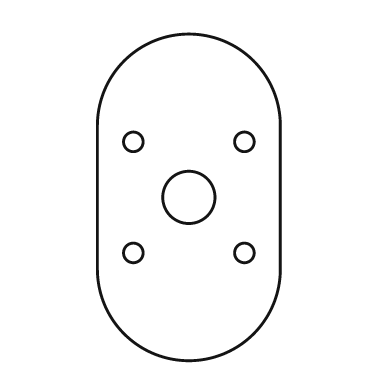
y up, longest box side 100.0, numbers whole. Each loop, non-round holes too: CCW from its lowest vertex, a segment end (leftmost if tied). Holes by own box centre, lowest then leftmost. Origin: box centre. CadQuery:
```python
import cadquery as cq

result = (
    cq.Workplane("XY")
    .moveTo(-28.0, -22.0)
    .threePointArc((0.0, -50.0), (28.0, -22.0))
    .lineTo(28.0, 22.0)
    .threePointArc((0.0, 50.0), (-28.0, 22.0))
    .close()
    .moveTo(-17.0, -17.0)
    .circle(3.0)
    .moveTo(17.0, -17.0)
    .circle(3.0)
    .moveTo(0.0, 0.0)
    .circle(8.0)
    .moveTo(-17.0, 17.0)
    .circle(3.0)
    .moveTo(17.0, 17.0)
    .circle(3.0)
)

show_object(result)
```